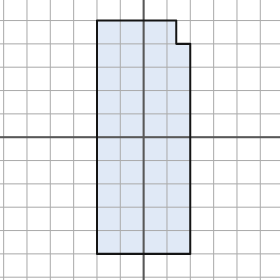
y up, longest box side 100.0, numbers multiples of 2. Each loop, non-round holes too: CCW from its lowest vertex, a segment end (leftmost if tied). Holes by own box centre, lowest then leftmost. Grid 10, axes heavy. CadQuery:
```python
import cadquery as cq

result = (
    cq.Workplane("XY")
    .moveTo(-20.0, -50.0)
    .lineTo(20.0, -50.0)
    .lineTo(20.0, 40.0)
    .lineTo(14.0, 40.0)
    .lineTo(14.0, 50.0)
    .lineTo(-20.0, 50.0)
    .close()
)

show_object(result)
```